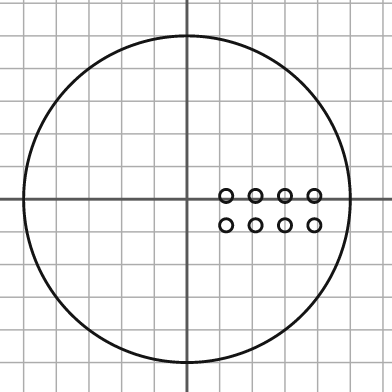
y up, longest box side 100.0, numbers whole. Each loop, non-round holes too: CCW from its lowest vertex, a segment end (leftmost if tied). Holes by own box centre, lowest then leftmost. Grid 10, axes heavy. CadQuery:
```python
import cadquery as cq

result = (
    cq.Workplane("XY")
    .moveTo(0.0, 0.0)
    .circle(50.0)
    .moveTo(12.0, -8.0)
    .circle(2.0)
    .moveTo(21.0, -8.0)
    .circle(2.0)
    .moveTo(30.0, -8.0)
    .circle(2.0)
    .moveTo(39.0, -8.0)
    .circle(2.0)
    .moveTo(12.0, 1.0)
    .circle(2.0)
    .moveTo(21.0, 1.0)
    .circle(2.0)
    .moveTo(30.0, 1.0)
    .circle(2.0)
    .moveTo(39.0, 1.0)
    .circle(2.0)
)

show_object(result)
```